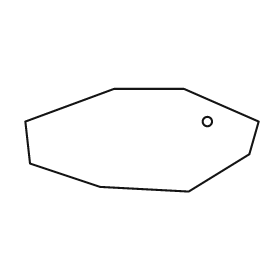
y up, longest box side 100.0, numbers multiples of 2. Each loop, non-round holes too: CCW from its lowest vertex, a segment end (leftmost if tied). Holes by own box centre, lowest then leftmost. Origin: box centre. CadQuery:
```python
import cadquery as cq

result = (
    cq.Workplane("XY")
    .moveTo(20.0, -22.0)
    .lineTo(46.0, -6.0)
    .lineTo(50.0, 8.0)
    .lineTo(18.0, 22.0)
    .lineTo(-12.0, 22.0)
    .lineTo(-50.0, 8.0)
    .lineTo(-48.0, -10.0)
    .lineTo(-18.0, -20.0)
    .close()
    .moveTo(28.0, 8.0)
    .circle(2.0)
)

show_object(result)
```